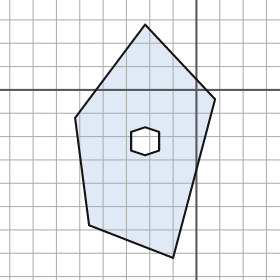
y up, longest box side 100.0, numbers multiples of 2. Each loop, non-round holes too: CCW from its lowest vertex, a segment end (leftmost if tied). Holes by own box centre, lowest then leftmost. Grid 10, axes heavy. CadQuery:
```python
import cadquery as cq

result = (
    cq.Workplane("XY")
    .moveTo(-10.0, -72.0)
    .lineTo(8.0, -4.0)
    .lineTo(-22.0, 28.0)
    .lineTo(-52.0, -12.0)
    .lineTo(-46.0, -58.0)
    .close()
    .moveTo(-22.0, -28.0)
    .lineTo(-16.0, -26.0)
    .lineTo(-16.0, -18.0)
    .lineTo(-22.0, -16.0)
    .lineTo(-28.0, -18.0)
    .lineTo(-28.0, -26.0)
    .close()
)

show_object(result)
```